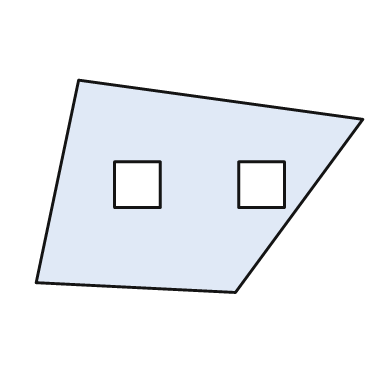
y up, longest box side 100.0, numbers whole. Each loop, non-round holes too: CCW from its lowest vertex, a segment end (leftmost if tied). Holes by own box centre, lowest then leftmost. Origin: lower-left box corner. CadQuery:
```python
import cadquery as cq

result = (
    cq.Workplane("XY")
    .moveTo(61.0, 0.0)
    .lineTo(100.0, 53.0)
    .lineTo(13.0, 65.0)
    .lineTo(0.0, 3.0)
    .close()
    .moveTo(24.0, 26.0)
    .lineTo(38.0, 26.0)
    .lineTo(38.0, 40.0)
    .lineTo(24.0, 40.0)
    .close()
    .moveTo(62.0, 26.0)
    .lineTo(76.0, 26.0)
    .lineTo(76.0, 40.0)
    .lineTo(62.0, 40.0)
    .close()
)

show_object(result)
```